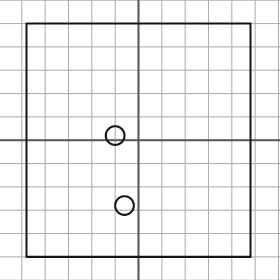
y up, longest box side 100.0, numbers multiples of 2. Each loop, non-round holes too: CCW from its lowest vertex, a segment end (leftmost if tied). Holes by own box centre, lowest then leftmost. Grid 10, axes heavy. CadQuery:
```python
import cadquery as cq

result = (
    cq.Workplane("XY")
    .moveTo(-48.0, -50.0)
    .lineTo(48.0, -50.0)
    .lineTo(48.0, 50.0)
    .lineTo(-48.0, 50.0)
    .close()
    .moveTo(-6.0, -28.0)
    .circle(4.0)
    .moveTo(-10.0, 2.0)
    .circle(4.0)
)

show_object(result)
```